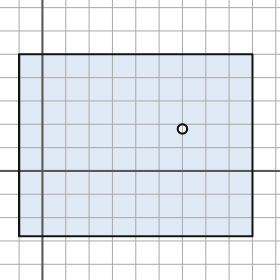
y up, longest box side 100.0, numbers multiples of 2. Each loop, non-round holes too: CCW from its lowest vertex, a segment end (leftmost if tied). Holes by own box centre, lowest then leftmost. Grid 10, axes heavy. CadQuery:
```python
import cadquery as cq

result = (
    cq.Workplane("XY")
    .moveTo(-10.0, -28.0)
    .lineTo(90.0, -28.0)
    .lineTo(90.0, 50.0)
    .lineTo(-10.0, 50.0)
    .close()
    .moveTo(60.0, 18.0)
    .circle(2.0)
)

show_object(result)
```